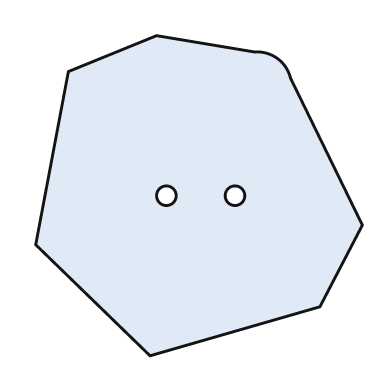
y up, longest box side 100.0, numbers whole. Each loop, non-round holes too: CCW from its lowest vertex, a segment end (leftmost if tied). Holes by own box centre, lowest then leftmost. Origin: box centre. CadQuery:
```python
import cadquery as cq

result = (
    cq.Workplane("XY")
    .moveTo(-15.0, -49.0)
    .lineTo(37.0, -34.0)
    .lineTo(50.0, -9.0)
    .lineTo(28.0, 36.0)
    .threePointArc((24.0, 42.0), (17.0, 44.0))
    .lineTo(-13.0, 49.0)
    .lineTo(-40.0, 38.0)
    .lineTo(-50.0, -15.0)
    .close()
    .moveTo(-10.0, 0.0)
    .circle(3.0)
    .moveTo(11.0, 0.0)
    .circle(3.0)
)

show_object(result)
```